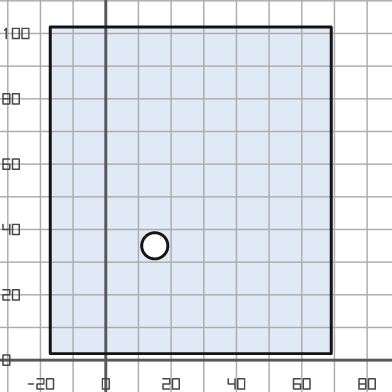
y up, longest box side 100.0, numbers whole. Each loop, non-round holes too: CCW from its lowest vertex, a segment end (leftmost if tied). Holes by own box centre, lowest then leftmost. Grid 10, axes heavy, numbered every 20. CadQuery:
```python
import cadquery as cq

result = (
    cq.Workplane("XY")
    .moveTo(-17.0, 2.0)
    .lineTo(69.0, 2.0)
    .lineTo(69.0, 102.0)
    .lineTo(-17.0, 102.0)
    .close()
    .moveTo(15.0, 35.0)
    .circle(4.0)
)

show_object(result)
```